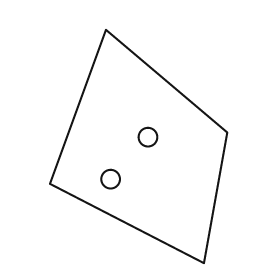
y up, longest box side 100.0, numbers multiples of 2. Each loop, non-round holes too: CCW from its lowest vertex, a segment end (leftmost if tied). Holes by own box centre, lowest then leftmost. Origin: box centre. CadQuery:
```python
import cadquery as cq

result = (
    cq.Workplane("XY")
    .moveTo(28.0, -50.0)
    .lineTo(38.0, 6.0)
    .lineTo(-14.0, 50.0)
    .lineTo(-38.0, -16.0)
    .close()
    .moveTo(-12.0, -14.0)
    .circle(4.0)
    .moveTo(4.0, 4.0)
    .circle(4.0)
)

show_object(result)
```